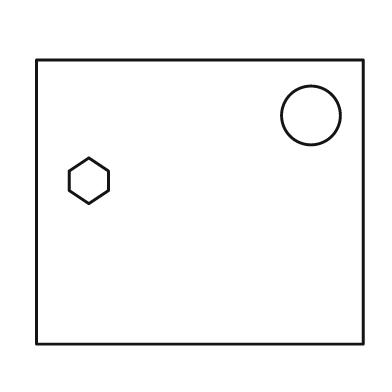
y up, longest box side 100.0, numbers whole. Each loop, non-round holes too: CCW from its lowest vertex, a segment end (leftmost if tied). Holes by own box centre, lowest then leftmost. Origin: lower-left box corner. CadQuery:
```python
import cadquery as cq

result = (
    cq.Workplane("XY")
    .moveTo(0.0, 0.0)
    .lineTo(100.0, 0.0)
    .lineTo(100.0, 87.0)
    .lineTo(0.0, 87.0)
    .close()
    .moveTo(16.0, 43.0)
    .lineTo(22.0, 47.0)
    .lineTo(22.0, 53.0)
    .lineTo(16.0, 57.0)
    .lineTo(10.0, 53.0)
    .lineTo(10.0, 47.0)
    .close()
    .moveTo(84.0, 70.0)
    .circle(9.0)
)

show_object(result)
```